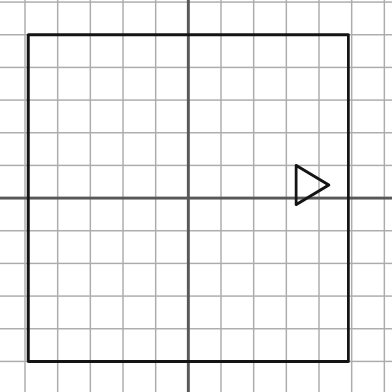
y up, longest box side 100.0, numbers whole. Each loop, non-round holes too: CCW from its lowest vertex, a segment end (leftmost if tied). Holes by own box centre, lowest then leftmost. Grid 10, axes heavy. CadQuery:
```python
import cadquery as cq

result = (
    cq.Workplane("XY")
    .moveTo(-49.0, -50.0)
    .lineTo(49.0, -50.0)
    .lineTo(49.0, 50.0)
    .lineTo(-49.0, 50.0)
    .close()
    .moveTo(33.0, -2.0)
    .lineTo(43.0, 4.0)
    .lineTo(33.0, 10.0)
    .close()
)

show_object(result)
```